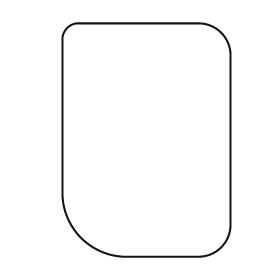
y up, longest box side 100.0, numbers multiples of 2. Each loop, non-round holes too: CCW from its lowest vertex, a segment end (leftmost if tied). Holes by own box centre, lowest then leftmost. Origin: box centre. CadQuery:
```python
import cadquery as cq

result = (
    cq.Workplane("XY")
    .moveTo(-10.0, -50.0)
    .lineTo(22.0, -50.0)
    .threePointArc((32.0, -46.0), (36.0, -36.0))
    .lineTo(36.0, 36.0)
    .threePointArc((32.0, 46.0), (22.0, 50.0))
    .lineTo(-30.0, 50.0)
    .threePointArc((-34.0, 48.0), (-36.0, 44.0))
    .lineTo(-36.0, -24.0)
    .threePointArc((-28.0, -42.0), (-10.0, -50.0))
    .close()
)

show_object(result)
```